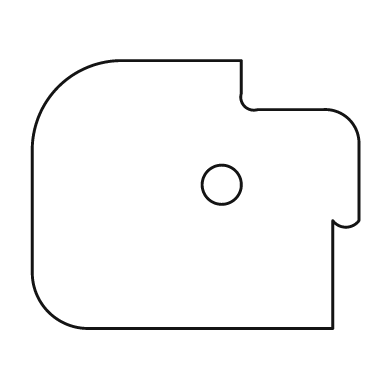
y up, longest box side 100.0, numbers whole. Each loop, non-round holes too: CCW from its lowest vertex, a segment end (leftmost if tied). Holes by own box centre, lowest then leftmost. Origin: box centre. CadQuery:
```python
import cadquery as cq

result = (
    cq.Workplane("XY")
    .moveTo(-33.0, -41.0)
    .lineTo(42.0, -41.0)
    .lineTo(42.0, -8.0)
    .threePointArc((46.0, -10.0), (50.0, -8.0))
    .lineTo(50.0, 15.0)
    .threePointArc((47.0, 23.0), (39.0, 26.0))
    .lineTo(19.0, 26.0)
    .threePointArc((15.0, 27.0), (14.0, 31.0))
    .lineTo(14.0, 41.0)
    .lineTo(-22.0, 41.0)
    .threePointArc((-42.0, 33.0), (-50.0, 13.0))
    .lineTo(-50.0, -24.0)
    .threePointArc((-45.0, -36.0), (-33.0, -41.0))
    .close()
    .moveTo(8.0, 3.0)
    .circle(6.0)
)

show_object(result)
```